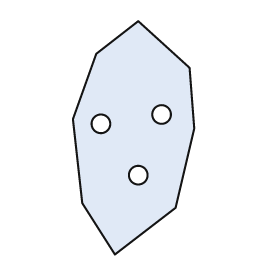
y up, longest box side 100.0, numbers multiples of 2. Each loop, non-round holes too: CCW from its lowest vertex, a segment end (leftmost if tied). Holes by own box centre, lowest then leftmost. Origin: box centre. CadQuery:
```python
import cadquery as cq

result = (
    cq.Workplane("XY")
    .moveTo(-8.0, -50.0)
    .lineTo(18.0, -30.0)
    .lineTo(26.0, 4.0)
    .lineTo(24.0, 30.0)
    .lineTo(2.0, 50.0)
    .lineTo(-16.0, 36.0)
    .lineTo(-26.0, 8.0)
    .lineTo(-22.0, -28.0)
    .close()
    .moveTo(2.0, -16.0)
    .circle(4.0)
    .moveTo(-14.0, 6.0)
    .circle(4.0)
    .moveTo(12.0, 10.0)
    .circle(4.0)
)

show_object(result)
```